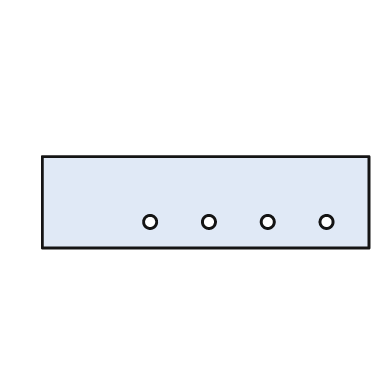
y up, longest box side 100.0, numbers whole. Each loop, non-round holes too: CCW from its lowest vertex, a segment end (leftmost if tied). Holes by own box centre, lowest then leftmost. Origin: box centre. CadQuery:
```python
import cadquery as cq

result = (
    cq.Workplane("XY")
    .moveTo(-50.0, -14.0)
    .lineTo(50.0, -14.0)
    .lineTo(50.0, 14.0)
    .lineTo(-50.0, 14.0)
    .close()
    .moveTo(-17.0, -6.0)
    .circle(2.0)
    .moveTo(1.0, -6.0)
    .circle(2.0)
    .moveTo(19.0, -6.0)
    .circle(2.0)
    .moveTo(37.0, -6.0)
    .circle(2.0)
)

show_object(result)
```